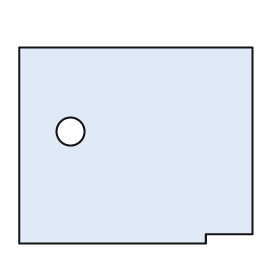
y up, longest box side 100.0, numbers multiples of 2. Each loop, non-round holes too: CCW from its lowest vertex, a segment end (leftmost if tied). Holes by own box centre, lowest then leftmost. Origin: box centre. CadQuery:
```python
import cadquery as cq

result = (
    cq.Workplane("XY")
    .moveTo(-50.0, -42.0)
    .lineTo(30.0, -42.0)
    .lineTo(30.0, -38.0)
    .lineTo(50.0, -38.0)
    .lineTo(50.0, 42.0)
    .lineTo(-50.0, 42.0)
    .close()
    .moveTo(-28.0, 6.0)
    .circle(6.0)
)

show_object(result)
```